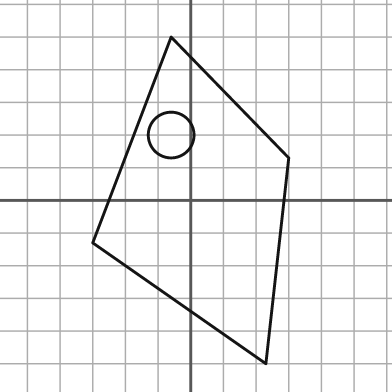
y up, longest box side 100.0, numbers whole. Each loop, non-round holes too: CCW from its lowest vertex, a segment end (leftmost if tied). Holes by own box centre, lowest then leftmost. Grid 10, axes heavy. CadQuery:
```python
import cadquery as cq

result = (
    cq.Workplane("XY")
    .moveTo(23.0, -50.0)
    .lineTo(30.0, 13.0)
    .lineTo(-6.0, 50.0)
    .lineTo(-30.0, -13.0)
    .close()
    .moveTo(-6.0, 20.0)
    .circle(7.0)
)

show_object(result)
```